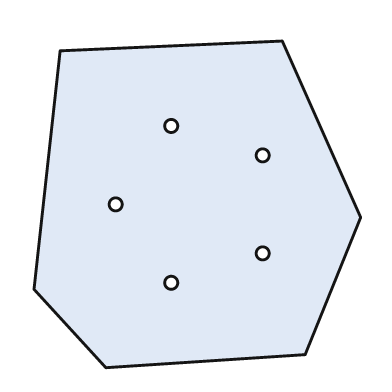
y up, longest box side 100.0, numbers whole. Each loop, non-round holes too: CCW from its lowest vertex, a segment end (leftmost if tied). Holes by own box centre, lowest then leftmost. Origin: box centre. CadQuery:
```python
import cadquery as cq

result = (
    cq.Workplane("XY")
    .moveTo(-28.0, -50.0)
    .lineTo(33.0, -46.0)
    .lineTo(50.0, -4.0)
    .lineTo(26.0, 50.0)
    .lineTo(-42.0, 47.0)
    .lineTo(-50.0, -26.0)
    .close()
    .moveTo(-8.0, -24.0)
    .circle(2.0)
    .moveTo(20.0, -15.0)
    .circle(2.0)
    .moveTo(-25.0, 0.0)
    .circle(2.0)
    .moveTo(20.0, 15.0)
    .circle(2.0)
    .moveTo(-8.0, 24.0)
    .circle(2.0)
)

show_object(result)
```